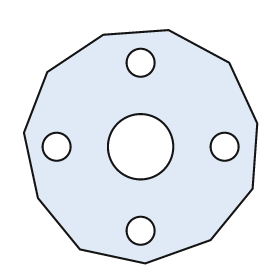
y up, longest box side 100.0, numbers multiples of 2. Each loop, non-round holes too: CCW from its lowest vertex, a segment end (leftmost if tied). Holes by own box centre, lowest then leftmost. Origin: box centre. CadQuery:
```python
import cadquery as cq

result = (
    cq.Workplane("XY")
    .moveTo(2.0, -50.0)
    .lineTo(30.0, -40.0)
    .lineTo(48.0, -18.0)
    .lineTo(50.0, 10.0)
    .lineTo(38.0, 36.0)
    .lineTo(12.0, 50.0)
    .lineTo(-16.0, 48.0)
    .lineTo(-40.0, 32.0)
    .lineTo(-50.0, 6.0)
    .lineTo(-44.0, -22.0)
    .lineTo(-26.0, -44.0)
    .close()
    .moveTo(0.0, -36.0)
    .circle(6.0)
    .moveTo(-36.0, 0.0)
    .circle(6.0)
    .moveTo(0.0, 0.0)
    .circle(14.0)
    .moveTo(36.0, 0.0)
    .circle(6.0)
    .moveTo(0.0, 36.0)
    .circle(6.0)
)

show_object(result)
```